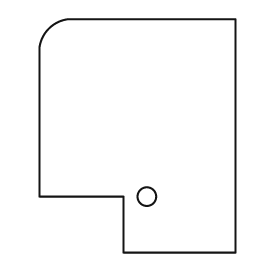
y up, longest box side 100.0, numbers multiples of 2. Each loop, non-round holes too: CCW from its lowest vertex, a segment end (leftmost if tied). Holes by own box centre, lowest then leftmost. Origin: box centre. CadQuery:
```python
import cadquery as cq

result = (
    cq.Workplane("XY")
    .moveTo(-6.0, -50.0)
    .lineTo(42.0, -50.0)
    .lineTo(42.0, 50.0)
    .lineTo(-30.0, 50.0)
    .threePointArc((-38.0, 46.0), (-42.0, 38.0))
    .lineTo(-42.0, -26.0)
    .lineTo(-6.0, -26.0)
    .close()
    .moveTo(4.0, -26.0)
    .circle(4.0)
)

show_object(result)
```